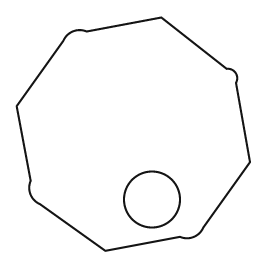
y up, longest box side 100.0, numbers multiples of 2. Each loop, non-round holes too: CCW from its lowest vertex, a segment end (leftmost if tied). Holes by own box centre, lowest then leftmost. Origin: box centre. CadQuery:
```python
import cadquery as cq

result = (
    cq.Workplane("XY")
    .moveTo(-12.0, -50.0)
    .lineTo(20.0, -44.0)
    .threePointArc((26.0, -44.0), (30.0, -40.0))
    .lineTo(50.0, -12.0)
    .lineTo(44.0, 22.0)
    .threePointArc((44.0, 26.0), (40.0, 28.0))
    .lineTo(12.0, 50.0)
    .lineTo(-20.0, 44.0)
    .threePointArc((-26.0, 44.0), (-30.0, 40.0))
    .lineTo(-50.0, 12.0)
    .lineTo(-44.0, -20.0)
    .threePointArc((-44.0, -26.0), (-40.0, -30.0))
    .close()
    .moveTo(8.0, -28.0)
    .circle(12.0)
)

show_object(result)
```